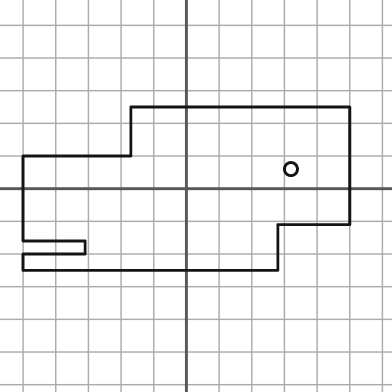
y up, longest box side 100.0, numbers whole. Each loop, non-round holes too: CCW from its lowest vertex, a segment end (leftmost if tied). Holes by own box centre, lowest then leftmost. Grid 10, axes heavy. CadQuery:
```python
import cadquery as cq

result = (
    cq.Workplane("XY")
    .moveTo(-50.0, -25.0)
    .lineTo(28.0, -25.0)
    .lineTo(28.0, -11.0)
    .lineTo(50.0, -11.0)
    .lineTo(50.0, 25.0)
    .lineTo(-17.0, 25.0)
    .lineTo(-17.0, 10.0)
    .lineTo(-50.0, 10.0)
    .lineTo(-50.0, -16.0)
    .lineTo(-31.0, -16.0)
    .lineTo(-31.0, -20.0)
    .lineTo(-50.0, -20.0)
    .close()
    .moveTo(32.0, 6.0)
    .circle(2.0)
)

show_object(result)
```